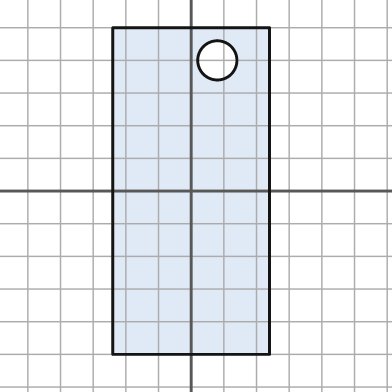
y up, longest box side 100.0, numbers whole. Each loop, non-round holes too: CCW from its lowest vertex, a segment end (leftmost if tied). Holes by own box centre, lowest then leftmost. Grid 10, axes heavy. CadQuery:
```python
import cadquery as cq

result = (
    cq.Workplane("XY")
    .moveTo(-24.0, -50.0)
    .lineTo(24.0, -50.0)
    .lineTo(24.0, 50.0)
    .lineTo(-24.0, 50.0)
    .close()
    .moveTo(8.0, 40.0)
    .circle(6.0)
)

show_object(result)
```